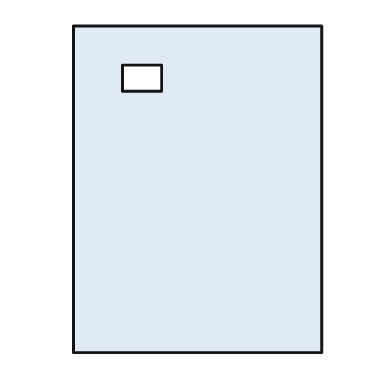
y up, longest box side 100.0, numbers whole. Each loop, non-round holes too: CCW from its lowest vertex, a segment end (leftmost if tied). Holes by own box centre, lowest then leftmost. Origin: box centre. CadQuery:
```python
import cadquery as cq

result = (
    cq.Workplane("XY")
    .moveTo(-38.0, -50.0)
    .lineTo(38.0, -50.0)
    .lineTo(38.0, 50.0)
    .lineTo(-38.0, 50.0)
    .close()
    .moveTo(-23.0, 30.0)
    .lineTo(-11.0, 30.0)
    .lineTo(-11.0, 38.0)
    .lineTo(-23.0, 38.0)
    .close()
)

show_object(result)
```